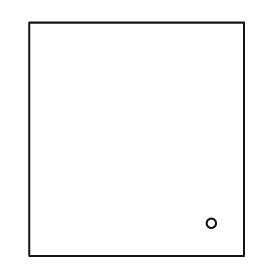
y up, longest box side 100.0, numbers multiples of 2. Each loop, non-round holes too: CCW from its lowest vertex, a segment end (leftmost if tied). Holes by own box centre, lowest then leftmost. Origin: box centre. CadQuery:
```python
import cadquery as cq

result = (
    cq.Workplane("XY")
    .moveTo(-46.0, -50.0)
    .lineTo(46.0, -50.0)
    .lineTo(46.0, 50.0)
    .lineTo(-46.0, 50.0)
    .close()
    .moveTo(32.0, -36.0)
    .circle(2.0)
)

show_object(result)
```